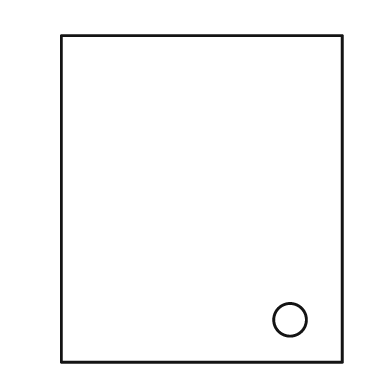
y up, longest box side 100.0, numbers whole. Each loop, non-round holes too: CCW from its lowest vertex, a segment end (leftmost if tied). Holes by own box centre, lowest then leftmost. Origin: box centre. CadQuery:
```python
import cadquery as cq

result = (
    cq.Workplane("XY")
    .moveTo(-43.0, -50.0)
    .lineTo(43.0, -50.0)
    .lineTo(43.0, 50.0)
    .lineTo(-43.0, 50.0)
    .close()
    .moveTo(27.0, -37.0)
    .circle(5.0)
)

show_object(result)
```